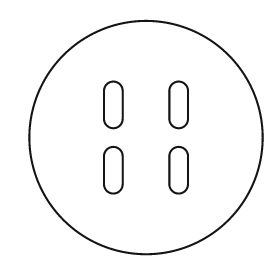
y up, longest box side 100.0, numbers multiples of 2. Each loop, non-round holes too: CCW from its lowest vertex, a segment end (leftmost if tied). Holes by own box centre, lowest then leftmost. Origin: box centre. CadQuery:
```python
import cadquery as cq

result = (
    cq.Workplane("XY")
    .moveTo(0.0, 0.0)
    .circle(50.0)
    .moveTo(-18.0, -20.0)
    .threePointArc((-14.0, -24.0), (-10.0, -20.0))
    .lineTo(-10.0, -8.0)
    .threePointArc((-14.0, -4.0), (-18.0, -8.0))
    .close()
    .moveTo(10.0, -20.0)
    .threePointArc((14.0, -24.0), (18.0, -20.0))
    .lineTo(18.0, -8.0)
    .threePointArc((14.0, -4.0), (10.0, -8.0))
    .close()
    .moveTo(-18.0, 8.0)
    .threePointArc((-14.0, 4.0), (-10.0, 8.0))
    .lineTo(-10.0, 20.0)
    .threePointArc((-14.0, 24.0), (-18.0, 20.0))
    .close()
    .moveTo(10.0, 8.0)
    .threePointArc((14.0, 4.0), (18.0, 8.0))
    .lineTo(18.0, 20.0)
    .threePointArc((14.0, 24.0), (10.0, 20.0))
    .close()
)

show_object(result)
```